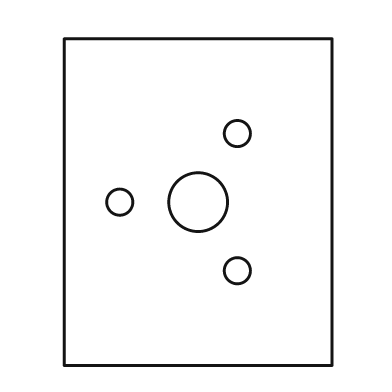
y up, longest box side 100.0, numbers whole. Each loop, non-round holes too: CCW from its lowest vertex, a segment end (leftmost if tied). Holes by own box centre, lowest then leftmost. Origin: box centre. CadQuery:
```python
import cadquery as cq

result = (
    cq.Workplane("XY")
    .moveTo(-41.0, -50.0)
    .lineTo(41.0, -50.0)
    .lineTo(41.0, 50.0)
    .lineTo(-41.0, 50.0)
    .close()
    .moveTo(12.0, -21.0)
    .circle(4.0)
    .moveTo(-24.0, 0.0)
    .circle(4.0)
    .moveTo(0.0, 0.0)
    .circle(9.0)
    .moveTo(12.0, 21.0)
    .circle(4.0)
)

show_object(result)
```